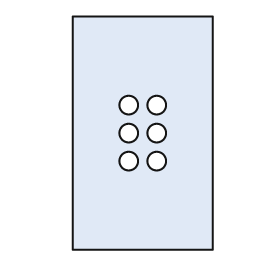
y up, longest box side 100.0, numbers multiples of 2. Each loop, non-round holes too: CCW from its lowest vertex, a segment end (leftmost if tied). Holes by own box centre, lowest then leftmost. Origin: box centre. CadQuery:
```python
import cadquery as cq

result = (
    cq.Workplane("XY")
    .moveTo(-30.0, -50.0)
    .lineTo(30.0, -50.0)
    .lineTo(30.0, 50.0)
    .lineTo(-30.0, 50.0)
    .close()
    .moveTo(-6.0, -12.0)
    .circle(4.0)
    .moveTo(6.0, -12.0)
    .circle(4.0)
    .moveTo(-6.0, 0.0)
    .circle(4.0)
    .moveTo(6.0, 0.0)
    .circle(4.0)
    .moveTo(-6.0, 12.0)
    .circle(4.0)
    .moveTo(6.0, 12.0)
    .circle(4.0)
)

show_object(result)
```